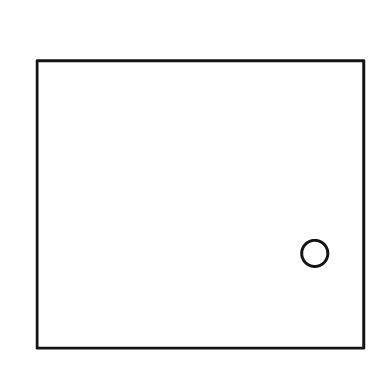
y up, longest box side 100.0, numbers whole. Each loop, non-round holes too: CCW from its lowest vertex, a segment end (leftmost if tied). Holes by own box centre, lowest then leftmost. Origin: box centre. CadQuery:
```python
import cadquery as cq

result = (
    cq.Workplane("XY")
    .moveTo(-50.0, -44.0)
    .lineTo(50.0, -44.0)
    .lineTo(50.0, 44.0)
    .lineTo(-50.0, 44.0)
    .close()
    .moveTo(35.0, -15.0)
    .circle(4.0)
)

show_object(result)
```